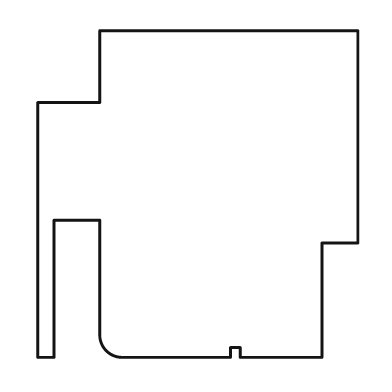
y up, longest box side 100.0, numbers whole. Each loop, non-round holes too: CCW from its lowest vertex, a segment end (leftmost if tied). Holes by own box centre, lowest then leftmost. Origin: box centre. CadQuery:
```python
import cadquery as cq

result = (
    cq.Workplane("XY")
    .moveTo(-49.0, -50.0)
    .lineTo(-44.0, -50.0)
    .lineTo(-44.0, -8.0)
    .lineTo(-30.0, -8.0)
    .lineTo(-30.0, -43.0)
    .threePointArc((-28.0, -48.0), (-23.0, -50.0))
    .lineTo(10.0, -50.0)
    .lineTo(10.0, -47.0)
    .lineTo(13.0, -47.0)
    .lineTo(13.0, -50.0)
    .lineTo(38.0, -50.0)
    .lineTo(38.0, -15.0)
    .lineTo(49.0, -15.0)
    .lineTo(49.0, 50.0)
    .lineTo(-30.0, 50.0)
    .lineTo(-30.0, 28.0)
    .lineTo(-49.0, 28.0)
    .close()
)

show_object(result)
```